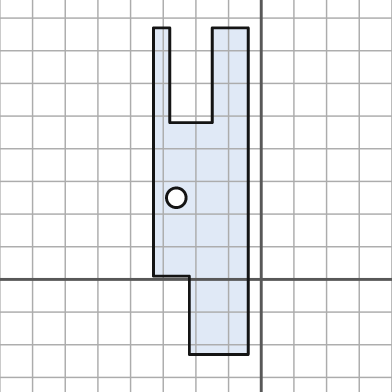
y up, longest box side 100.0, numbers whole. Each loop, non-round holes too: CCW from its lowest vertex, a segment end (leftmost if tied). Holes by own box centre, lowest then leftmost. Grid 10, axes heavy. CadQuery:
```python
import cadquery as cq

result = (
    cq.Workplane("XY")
    .moveTo(-22.0, -23.0)
    .lineTo(-4.0, -23.0)
    .lineTo(-4.0, 77.0)
    .lineTo(-15.0, 77.0)
    .lineTo(-15.0, 48.0)
    .lineTo(-28.0, 48.0)
    .lineTo(-28.0, 77.0)
    .lineTo(-33.0, 77.0)
    .lineTo(-33.0, 1.0)
    .lineTo(-22.0, 1.0)
    .close()
    .moveTo(-26.0, 25.0)
    .circle(3.0)
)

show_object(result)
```